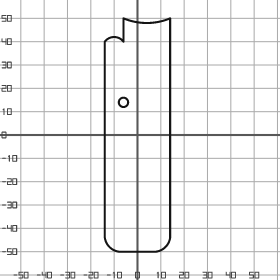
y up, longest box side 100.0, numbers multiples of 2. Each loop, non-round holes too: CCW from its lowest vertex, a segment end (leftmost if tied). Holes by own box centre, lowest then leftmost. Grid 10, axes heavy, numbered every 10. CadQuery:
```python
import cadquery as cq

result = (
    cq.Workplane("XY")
    .moveTo(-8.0, -50.0)
    .lineTo(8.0, -50.0)
    .threePointArc((12.0, -48.0), (14.0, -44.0))
    .lineTo(14.0, 50.0)
    .threePointArc((4.0, 48.0), (-6.0, 50.0))
    .lineTo(-6.0, 40.0)
    .threePointArc((-10.0, 42.0), (-14.0, 40.0))
    .lineTo(-14.0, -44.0)
    .threePointArc((-12.0, -48.0), (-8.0, -50.0))
    .close()
    .moveTo(-6.0, 14.0)
    .circle(2.0)
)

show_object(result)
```